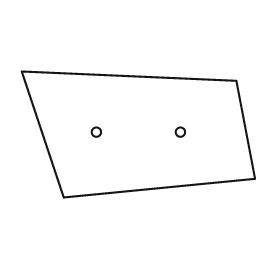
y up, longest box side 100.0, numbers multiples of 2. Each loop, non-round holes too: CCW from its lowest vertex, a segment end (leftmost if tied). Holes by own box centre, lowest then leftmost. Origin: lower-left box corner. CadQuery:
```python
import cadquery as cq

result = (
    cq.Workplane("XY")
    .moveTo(18.0, 0.0)
    .lineTo(100.0, 8.0)
    .lineTo(92.0, 50.0)
    .lineTo(0.0, 54.0)
    .close()
    .moveTo(32.0, 28.0)
    .circle(2.0)
    .moveTo(68.0, 28.0)
    .circle(2.0)
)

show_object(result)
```